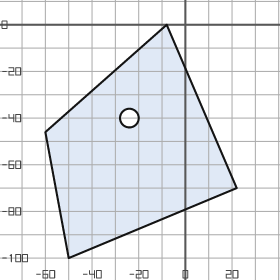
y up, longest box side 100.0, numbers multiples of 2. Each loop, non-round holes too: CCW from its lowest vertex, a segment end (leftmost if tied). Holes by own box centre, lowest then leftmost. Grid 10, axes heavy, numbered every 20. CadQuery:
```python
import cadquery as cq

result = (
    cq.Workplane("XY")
    .moveTo(-50.0, -100.0)
    .lineTo(22.0, -70.0)
    .lineTo(-8.0, 0.0)
    .lineTo(-60.0, -46.0)
    .close()
    .moveTo(-24.0, -40.0)
    .circle(4.0)
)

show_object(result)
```